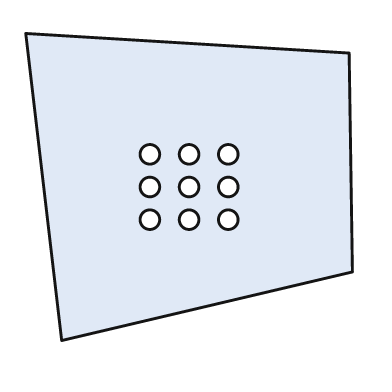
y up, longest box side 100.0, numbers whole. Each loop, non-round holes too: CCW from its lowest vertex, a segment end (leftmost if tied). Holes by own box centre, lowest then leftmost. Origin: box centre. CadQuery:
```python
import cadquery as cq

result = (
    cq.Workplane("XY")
    .moveTo(-39.0, -47.0)
    .lineTo(50.0, -26.0)
    .lineTo(49.0, 41.0)
    .lineTo(-50.0, 47.0)
    .close()
    .moveTo(-12.0, -10.0)
    .circle(3.0)
    .moveTo(0.0, -10.0)
    .circle(3.0)
    .moveTo(12.0, -10.0)
    .circle(3.0)
    .moveTo(-12.0, 0.0)
    .circle(3.0)
    .moveTo(0.0, 0.0)
    .circle(3.0)
    .moveTo(12.0, 0.0)
    .circle(3.0)
    .moveTo(-12.0, 10.0)
    .circle(3.0)
    .moveTo(0.0, 10.0)
    .circle(3.0)
    .moveTo(12.0, 10.0)
    .circle(3.0)
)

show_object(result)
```